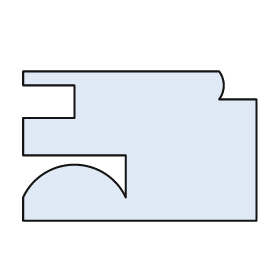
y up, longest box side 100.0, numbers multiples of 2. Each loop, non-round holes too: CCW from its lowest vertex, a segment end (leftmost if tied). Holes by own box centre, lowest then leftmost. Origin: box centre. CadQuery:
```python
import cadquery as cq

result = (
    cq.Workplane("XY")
    .moveTo(-50.0, -32.0)
    .lineTo(50.0, -32.0)
    .lineTo(50.0, 20.0)
    .lineTo(34.0, 20.0)
    .threePointArc((36.0, 26.0), (34.0, 32.0))
    .lineTo(-50.0, 32.0)
    .lineTo(-50.0, 26.0)
    .lineTo(-28.0, 26.0)
    .lineTo(-28.0, 12.0)
    .lineTo(-50.0, 12.0)
    .lineTo(-50.0, -4.0)
    .lineTo(-6.0, -4.0)
    .lineTo(-6.0, -22.0)
    .threePointArc((-28.0, -8.0), (-50.0, -22.0))
    .close()
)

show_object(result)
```